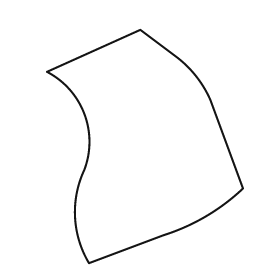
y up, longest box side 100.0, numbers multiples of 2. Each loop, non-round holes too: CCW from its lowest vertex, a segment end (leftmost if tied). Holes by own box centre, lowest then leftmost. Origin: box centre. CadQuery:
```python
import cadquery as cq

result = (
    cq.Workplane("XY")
    .moveTo(-24.0, -50.0)
    .lineTo(8.0, -38.0)
    .threePointArc((26.0, -30.0), (42.0, -18.0))
    .lineTo(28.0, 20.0)
    .threePointArc((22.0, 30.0), (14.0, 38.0))
    .lineTo(-2.0, 50.0)
    .lineTo(-42.0, 32.0)
    .threePointArc((-26.0, 14.0), (-26.0, -10.0))
    .threePointArc((-30.0, -30.0), (-24.0, -50.0))
    .close()
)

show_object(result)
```